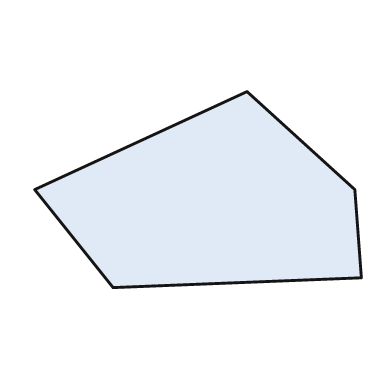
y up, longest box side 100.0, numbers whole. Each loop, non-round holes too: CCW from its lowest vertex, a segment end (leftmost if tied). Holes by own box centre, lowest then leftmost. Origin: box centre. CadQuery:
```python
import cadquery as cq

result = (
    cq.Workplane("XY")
    .moveTo(-26.0, -30.0)
    .lineTo(50.0, -27.0)
    .lineTo(48.0, 0.0)
    .lineTo(15.0, 30.0)
    .lineTo(-50.0, 0.0)
    .close()
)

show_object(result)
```